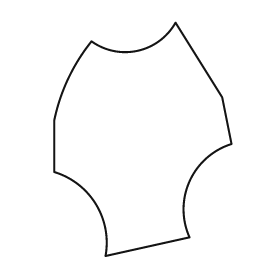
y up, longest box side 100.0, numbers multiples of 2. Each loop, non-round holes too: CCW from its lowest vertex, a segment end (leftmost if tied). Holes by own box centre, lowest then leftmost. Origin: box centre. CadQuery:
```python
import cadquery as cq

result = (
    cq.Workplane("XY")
    .moveTo(-16.0, -50.0)
    .lineTo(20.0, -42.0)
    .threePointArc((20.0, -18.0), (38.0, -2.0))
    .lineTo(34.0, 18.0)
    .lineTo(14.0, 50.0)
    .threePointArc((-2.0, 38.0), (-22.0, 42.0))
    .threePointArc((-32.0, 26.0), (-38.0, 8.0))
    .lineTo(-38.0, -14.0)
    .threePointArc((-20.0, -28.0), (-16.0, -50.0))
    .close()
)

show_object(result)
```